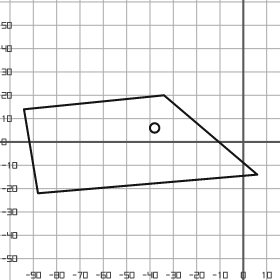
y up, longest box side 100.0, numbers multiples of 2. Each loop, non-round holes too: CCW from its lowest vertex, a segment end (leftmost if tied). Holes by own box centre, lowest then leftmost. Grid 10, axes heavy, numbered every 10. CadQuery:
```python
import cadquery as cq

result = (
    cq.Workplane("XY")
    .moveTo(-88.0, -22.0)
    .lineTo(6.0, -14.0)
    .lineTo(-34.0, 20.0)
    .lineTo(-94.0, 14.0)
    .close()
    .moveTo(-38.0, 6.0)
    .circle(2.0)
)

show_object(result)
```